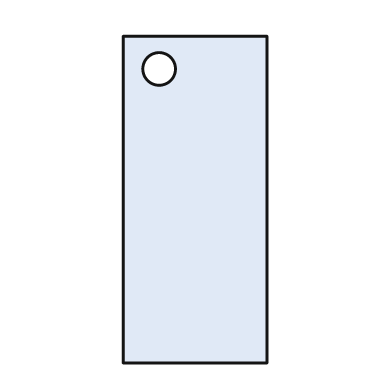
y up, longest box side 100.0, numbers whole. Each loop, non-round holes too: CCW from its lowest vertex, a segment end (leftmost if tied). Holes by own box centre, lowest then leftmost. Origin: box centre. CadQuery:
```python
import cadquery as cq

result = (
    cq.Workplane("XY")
    .moveTo(-22.0, -50.0)
    .lineTo(22.0, -50.0)
    .lineTo(22.0, 50.0)
    .lineTo(-22.0, 50.0)
    .close()
    .moveTo(-11.0, 40.0)
    .circle(5.0)
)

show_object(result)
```